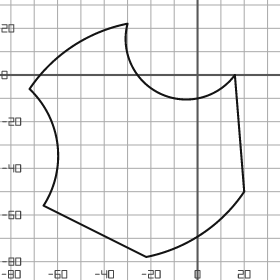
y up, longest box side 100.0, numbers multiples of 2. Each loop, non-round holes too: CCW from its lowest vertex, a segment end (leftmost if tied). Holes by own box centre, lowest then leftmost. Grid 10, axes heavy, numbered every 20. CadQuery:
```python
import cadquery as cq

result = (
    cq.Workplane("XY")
    .moveTo(-22.0, -78.0)
    .threePointArc((2.0, -68.0), (20.0, -50.0))
    .lineTo(16.0, 0.0)
    .threePointArc((-16.0, -8.0), (-30.0, 22.0))
    .threePointArc((-54.0, 12.0), (-72.0, -6.0))
    .threePointArc((-60.0, -30.0), (-66.0, -56.0))
    .close()
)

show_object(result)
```